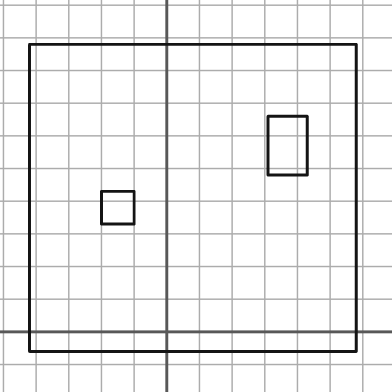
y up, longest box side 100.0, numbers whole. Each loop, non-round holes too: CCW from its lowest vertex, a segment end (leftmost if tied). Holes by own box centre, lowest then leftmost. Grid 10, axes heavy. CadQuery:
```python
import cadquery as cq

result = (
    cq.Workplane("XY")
    .moveTo(-42.0, -6.0)
    .lineTo(58.0, -6.0)
    .lineTo(58.0, 88.0)
    .lineTo(-42.0, 88.0)
    .close()
    .moveTo(-20.0, 33.0)
    .lineTo(-10.0, 33.0)
    .lineTo(-10.0, 43.0)
    .lineTo(-20.0, 43.0)
    .close()
    .moveTo(31.0, 48.0)
    .lineTo(43.0, 48.0)
    .lineTo(43.0, 66.0)
    .lineTo(31.0, 66.0)
    .close()
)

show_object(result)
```